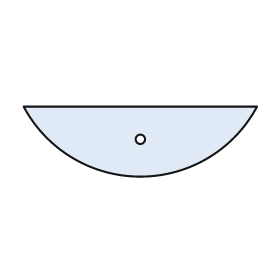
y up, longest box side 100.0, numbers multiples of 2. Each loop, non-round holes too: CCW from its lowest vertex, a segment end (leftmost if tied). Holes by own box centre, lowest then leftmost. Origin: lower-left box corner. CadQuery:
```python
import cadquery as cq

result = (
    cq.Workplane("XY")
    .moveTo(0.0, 30.0)
    .threePointArc((50.0, 0.0), (100.0, 30.0))
    .close()
    .moveTo(50.0, 16.0)
    .circle(2.0)
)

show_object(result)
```